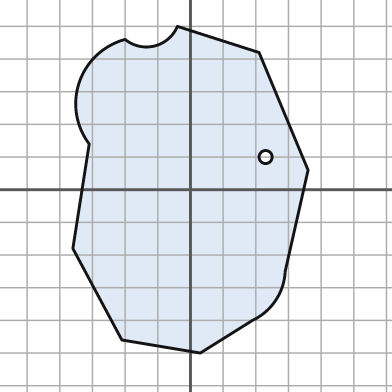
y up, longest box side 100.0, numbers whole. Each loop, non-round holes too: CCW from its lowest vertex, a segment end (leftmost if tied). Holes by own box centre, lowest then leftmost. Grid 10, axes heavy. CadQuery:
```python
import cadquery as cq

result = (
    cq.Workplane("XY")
    .moveTo(3.0, -50.0)
    .lineTo(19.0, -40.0)
    .threePointArc((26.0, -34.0), (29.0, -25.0))
    .lineTo(36.0, 6.0)
    .lineTo(21.0, 42.0)
    .lineTo(-4.0, 50.0)
    .threePointArc((-11.0, 44.0), (-20.0, 46.0))
    .threePointArc((-34.0, 33.0), (-31.0, 14.0))
    .lineTo(-36.0, -18.0)
    .lineTo(-21.0, -46.0)
    .close()
    .moveTo(23.0, 10.0)
    .circle(2.0)
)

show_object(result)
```